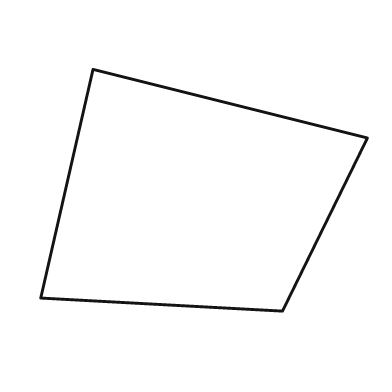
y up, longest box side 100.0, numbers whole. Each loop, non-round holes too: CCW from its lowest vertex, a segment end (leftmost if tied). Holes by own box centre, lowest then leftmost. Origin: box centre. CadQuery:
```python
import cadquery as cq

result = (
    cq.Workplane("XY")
    .moveTo(24.0, -37.0)
    .lineTo(50.0, 16.0)
    .lineTo(-34.0, 37.0)
    .lineTo(-50.0, -33.0)
    .close()
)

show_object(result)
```